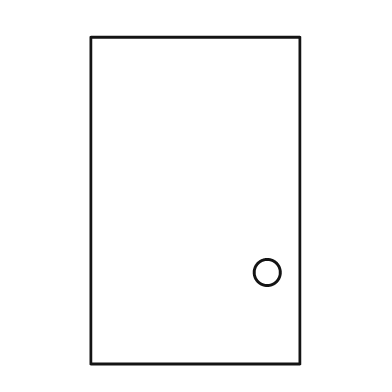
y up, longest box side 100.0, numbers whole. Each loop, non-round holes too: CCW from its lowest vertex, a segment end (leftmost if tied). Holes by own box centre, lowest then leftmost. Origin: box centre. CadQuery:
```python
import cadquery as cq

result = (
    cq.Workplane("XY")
    .moveTo(-32.0, -50.0)
    .lineTo(32.0, -50.0)
    .lineTo(32.0, 50.0)
    .lineTo(-32.0, 50.0)
    .close()
    .moveTo(22.0, -22.0)
    .circle(4.0)
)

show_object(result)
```